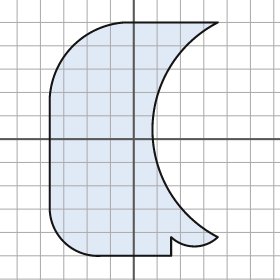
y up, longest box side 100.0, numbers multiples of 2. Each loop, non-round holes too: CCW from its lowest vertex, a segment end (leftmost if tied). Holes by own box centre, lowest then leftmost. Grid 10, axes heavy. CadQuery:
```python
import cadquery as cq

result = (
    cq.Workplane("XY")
    .moveTo(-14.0, -50.0)
    .lineTo(16.0, -50.0)
    .lineTo(16.0, -42.0)
    .threePointArc((26.0, -46.0), (36.0, -42.0))
    .threePointArc((8.0, 4.0), (36.0, 50.0))
    .lineTo(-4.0, 50.0)
    .threePointArc((-26.0, 40.0), (-36.0, 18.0))
    .lineTo(-36.0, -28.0)
    .threePointArc((-30.0, -44.0), (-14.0, -50.0))
    .close()
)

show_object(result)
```